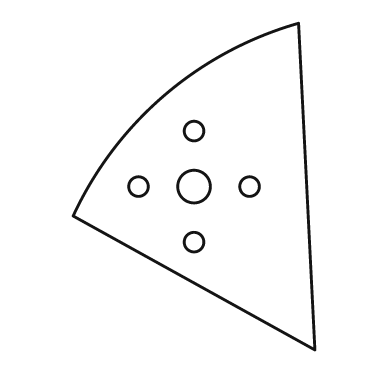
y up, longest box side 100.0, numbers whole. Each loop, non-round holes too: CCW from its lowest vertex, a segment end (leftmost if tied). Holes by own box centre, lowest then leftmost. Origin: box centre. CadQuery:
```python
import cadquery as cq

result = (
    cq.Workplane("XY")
    .moveTo(37.0, -50.0)
    .lineTo(32.0, 50.0)
    .threePointArc((-9.0, 28.0), (-37.0, -9.0))
    .close()
    .moveTo(0.0, -17.0)
    .circle(3.0)
    .moveTo(-17.0, 0.0)
    .circle(3.0)
    .moveTo(0.0, 0.0)
    .circle(5.0)
    .moveTo(17.0, 0.0)
    .circle(3.0)
    .moveTo(0.0, 17.0)
    .circle(3.0)
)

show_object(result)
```